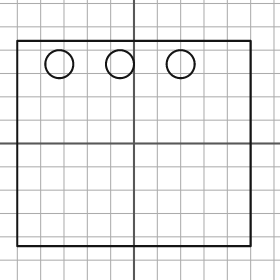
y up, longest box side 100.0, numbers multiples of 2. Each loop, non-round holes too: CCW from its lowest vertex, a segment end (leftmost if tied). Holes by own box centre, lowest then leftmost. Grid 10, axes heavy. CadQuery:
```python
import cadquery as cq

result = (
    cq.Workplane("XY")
    .moveTo(-50.0, -44.0)
    .lineTo(50.0, -44.0)
    .lineTo(50.0, 44.0)
    .lineTo(-50.0, 44.0)
    .close()
    .moveTo(-32.0, 34.0)
    .circle(6.0)
    .moveTo(-6.0, 34.0)
    .circle(6.0)
    .moveTo(20.0, 34.0)
    .circle(6.0)
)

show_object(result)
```